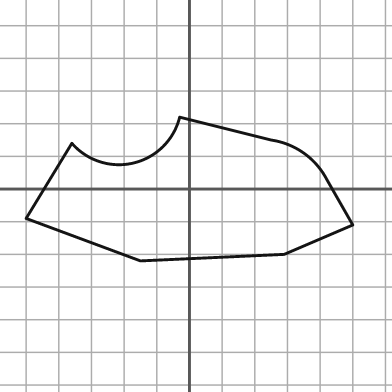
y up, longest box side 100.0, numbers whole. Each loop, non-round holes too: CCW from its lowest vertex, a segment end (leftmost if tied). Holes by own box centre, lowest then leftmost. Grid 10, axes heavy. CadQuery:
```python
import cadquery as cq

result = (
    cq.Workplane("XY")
    .moveTo(-15.0, -22.0)
    .lineTo(29.0, -20.0)
    .lineTo(50.0, -11.0)
    .lineTo(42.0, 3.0)
    .threePointArc((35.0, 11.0), (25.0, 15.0))
    .lineTo(-3.0, 22.0)
    .threePointArc((-17.0, 8.0), (-36.0, 14.0))
    .lineTo(-50.0, -9.0)
    .close()
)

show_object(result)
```